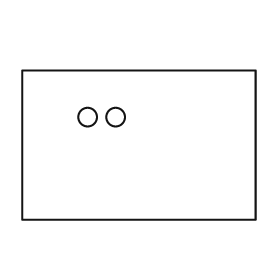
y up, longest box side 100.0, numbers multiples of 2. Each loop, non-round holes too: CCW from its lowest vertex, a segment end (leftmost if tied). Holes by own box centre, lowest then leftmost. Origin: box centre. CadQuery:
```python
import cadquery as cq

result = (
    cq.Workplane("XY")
    .moveTo(-50.0, -32.0)
    .lineTo(50.0, -32.0)
    .lineTo(50.0, 32.0)
    .lineTo(-50.0, 32.0)
    .close()
    .moveTo(-22.0, 12.0)
    .circle(4.0)
    .moveTo(-10.0, 12.0)
    .circle(4.0)
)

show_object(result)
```